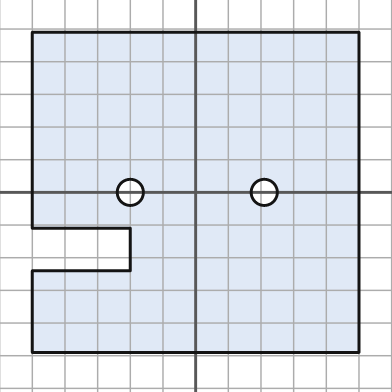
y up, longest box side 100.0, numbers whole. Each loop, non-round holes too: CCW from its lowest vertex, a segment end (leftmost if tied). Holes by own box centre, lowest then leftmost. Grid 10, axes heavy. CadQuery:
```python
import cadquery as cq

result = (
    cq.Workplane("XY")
    .moveTo(-50.0, -49.0)
    .lineTo(50.0, -49.0)
    .lineTo(50.0, 49.0)
    .lineTo(-50.0, 49.0)
    .lineTo(-50.0, -11.0)
    .lineTo(-20.0, -11.0)
    .lineTo(-20.0, -24.0)
    .lineTo(-50.0, -24.0)
    .close()
    .moveTo(-20.0, 0.0)
    .circle(4.0)
    .moveTo(21.0, 0.0)
    .circle(4.0)
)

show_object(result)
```